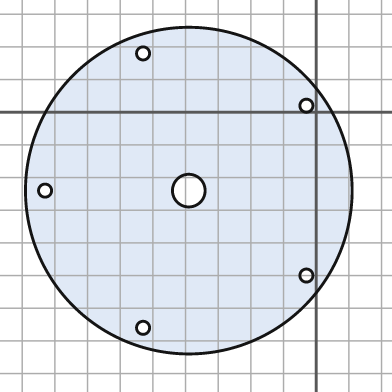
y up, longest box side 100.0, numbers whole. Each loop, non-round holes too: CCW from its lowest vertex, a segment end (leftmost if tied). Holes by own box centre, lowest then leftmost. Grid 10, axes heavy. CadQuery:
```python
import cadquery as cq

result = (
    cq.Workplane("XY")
    .moveTo(-39.0, -24.0)
    .circle(50.0)
    .moveTo(-53.0, -66.0)
    .circle(2.0)
    .moveTo(-3.0, -50.0)
    .circle(2.0)
    .moveTo(-83.0, -24.0)
    .circle(2.0)
    .moveTo(-39.0, -24.0)
    .circle(5.0)
    .moveTo(-3.0, 2.0)
    .circle(2.0)
    .moveTo(-53.0, 18.0)
    .circle(2.0)
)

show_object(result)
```